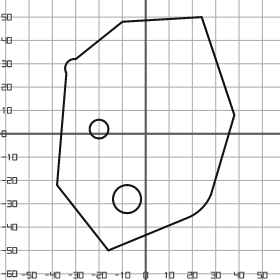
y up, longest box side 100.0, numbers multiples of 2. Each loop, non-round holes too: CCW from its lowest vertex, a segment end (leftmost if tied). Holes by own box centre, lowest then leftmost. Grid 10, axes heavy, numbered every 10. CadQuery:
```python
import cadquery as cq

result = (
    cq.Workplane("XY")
    .moveTo(-16.0, -50.0)
    .lineTo(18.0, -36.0)
    .threePointArc((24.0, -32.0), (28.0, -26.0))
    .lineTo(38.0, 8.0)
    .lineTo(24.0, 50.0)
    .lineTo(-10.0, 48.0)
    .lineTo(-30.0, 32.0)
    .threePointArc((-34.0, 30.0), (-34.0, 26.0))
    .lineTo(-38.0, -22.0)
    .close()
    .moveTo(-8.0, -28.0)
    .circle(6.0)
    .moveTo(-20.0, 2.0)
    .circle(4.0)
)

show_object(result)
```